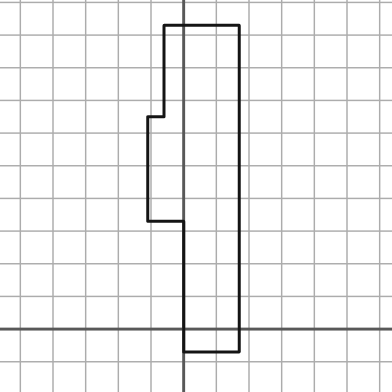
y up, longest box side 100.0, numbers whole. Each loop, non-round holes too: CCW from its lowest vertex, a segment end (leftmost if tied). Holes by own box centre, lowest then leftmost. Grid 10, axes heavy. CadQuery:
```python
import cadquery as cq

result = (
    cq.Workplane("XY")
    .moveTo(0.0, -7.0)
    .lineTo(17.0, -7.0)
    .lineTo(17.0, 93.0)
    .lineTo(-6.0, 93.0)
    .lineTo(-6.0, 65.0)
    .lineTo(-11.0, 65.0)
    .lineTo(-11.0, 33.0)
    .lineTo(0.0, 33.0)
    .close()
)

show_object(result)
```